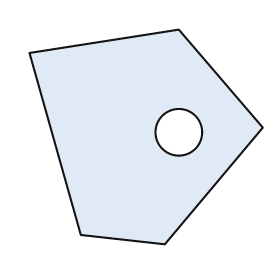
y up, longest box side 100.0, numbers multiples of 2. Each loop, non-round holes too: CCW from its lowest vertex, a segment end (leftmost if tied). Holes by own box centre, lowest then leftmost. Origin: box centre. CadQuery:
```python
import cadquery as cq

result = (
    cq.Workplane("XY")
    .moveTo(8.0, -46.0)
    .lineTo(50.0, 4.0)
    .lineTo(14.0, 46.0)
    .lineTo(-50.0, 36.0)
    .lineTo(-28.0, -42.0)
    .close()
    .moveTo(14.0, 2.0)
    .circle(10.0)
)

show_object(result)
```